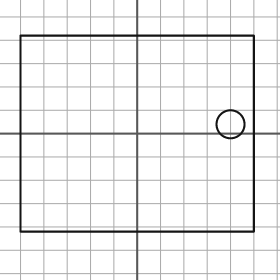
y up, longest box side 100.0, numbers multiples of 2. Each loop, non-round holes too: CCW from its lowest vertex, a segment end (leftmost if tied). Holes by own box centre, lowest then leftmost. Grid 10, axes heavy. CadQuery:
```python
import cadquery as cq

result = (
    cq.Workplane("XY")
    .moveTo(-50.0, -42.0)
    .lineTo(50.0, -42.0)
    .lineTo(50.0, 42.0)
    .lineTo(-50.0, 42.0)
    .close()
    .moveTo(40.0, 4.0)
    .circle(6.0)
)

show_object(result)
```